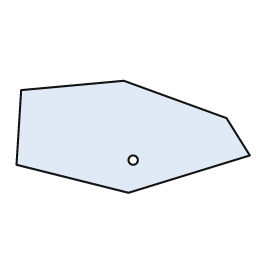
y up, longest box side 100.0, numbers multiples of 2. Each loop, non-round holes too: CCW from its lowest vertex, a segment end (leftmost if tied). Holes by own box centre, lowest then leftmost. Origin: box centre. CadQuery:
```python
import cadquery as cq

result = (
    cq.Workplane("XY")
    .moveTo(-2.0, -24.0)
    .lineTo(50.0, -8.0)
    .lineTo(40.0, 8.0)
    .lineTo(-4.0, 24.0)
    .lineTo(-48.0, 20.0)
    .lineTo(-50.0, -12.0)
    .close()
    .moveTo(0.0, -10.0)
    .circle(2.0)
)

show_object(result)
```